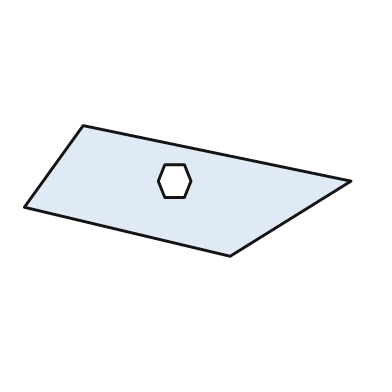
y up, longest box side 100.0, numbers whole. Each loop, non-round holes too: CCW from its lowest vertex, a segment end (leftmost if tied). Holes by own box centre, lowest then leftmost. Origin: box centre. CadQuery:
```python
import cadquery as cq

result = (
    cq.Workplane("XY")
    .moveTo(13.0, -20.0)
    .lineTo(50.0, 3.0)
    .lineTo(-32.0, 20.0)
    .lineTo(-50.0, -5.0)
    .close()
    .moveTo(-7.0, -2.0)
    .lineTo(-1.0, -2.0)
    .lineTo(1.0, 3.0)
    .lineTo(-1.0, 8.0)
    .lineTo(-7.0, 8.0)
    .lineTo(-9.0, 3.0)
    .close()
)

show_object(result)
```